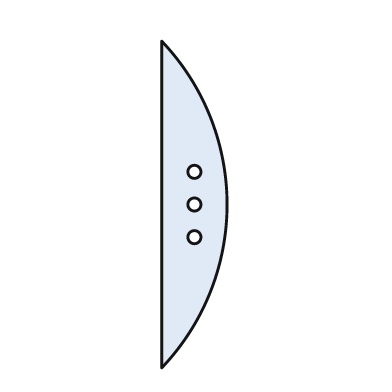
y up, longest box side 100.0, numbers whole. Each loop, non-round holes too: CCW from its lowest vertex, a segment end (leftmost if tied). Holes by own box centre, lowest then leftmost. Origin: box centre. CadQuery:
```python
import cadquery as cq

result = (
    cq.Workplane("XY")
    .moveTo(-10.0, -50.0)
    .threePointArc((10.0, 0.0), (-10.0, 50.0))
    .close()
    .moveTo(0.0, -10.0)
    .circle(2.0)
    .moveTo(0.0, 0.0)
    .circle(2.0)
    .moveTo(0.0, 10.0)
    .circle(2.0)
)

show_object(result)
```